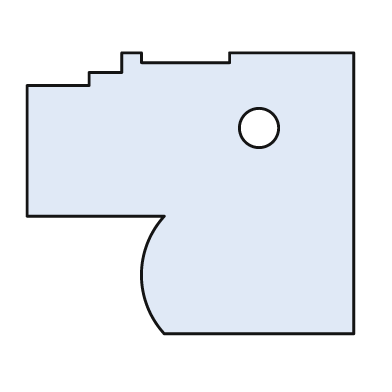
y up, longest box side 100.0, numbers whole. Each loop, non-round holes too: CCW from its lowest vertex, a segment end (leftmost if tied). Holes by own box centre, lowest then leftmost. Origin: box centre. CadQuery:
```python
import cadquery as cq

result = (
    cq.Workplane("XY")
    .moveTo(-8.0, -43.0)
    .lineTo(50.0, -43.0)
    .lineTo(50.0, 43.0)
    .lineTo(12.0, 43.0)
    .lineTo(12.0, 40.0)
    .lineTo(-15.0, 40.0)
    .lineTo(-15.0, 43.0)
    .lineTo(-21.0, 43.0)
    .lineTo(-21.0, 37.0)
    .lineTo(-31.0, 37.0)
    .lineTo(-31.0, 33.0)
    .lineTo(-50.0, 33.0)
    .lineTo(-50.0, -7.0)
    .lineTo(-8.0, -7.0)
    .threePointArc((-15.0, -25.0), (-8.0, -43.0))
    .close()
    .moveTo(21.0, 20.0)
    .circle(6.0)
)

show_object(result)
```